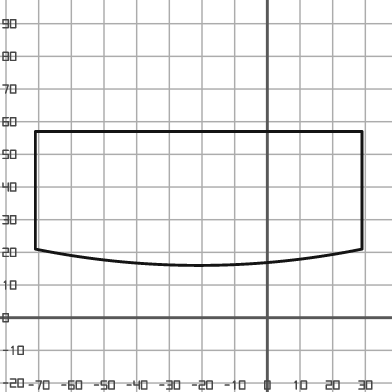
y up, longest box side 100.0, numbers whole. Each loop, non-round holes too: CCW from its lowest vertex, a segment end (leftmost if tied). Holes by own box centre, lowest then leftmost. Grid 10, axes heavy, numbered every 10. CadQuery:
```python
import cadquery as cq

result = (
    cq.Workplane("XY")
    .moveTo(-71.0, 21.0)
    .threePointArc((-21.0, 16.0), (29.0, 21.0))
    .lineTo(29.0, 57.0)
    .lineTo(-71.0, 57.0)
    .close()
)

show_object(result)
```